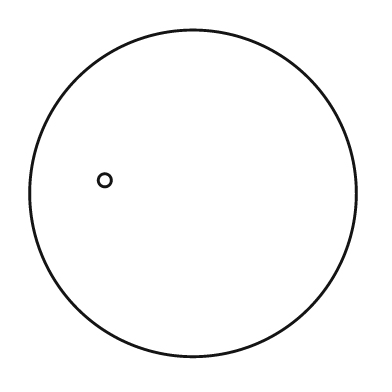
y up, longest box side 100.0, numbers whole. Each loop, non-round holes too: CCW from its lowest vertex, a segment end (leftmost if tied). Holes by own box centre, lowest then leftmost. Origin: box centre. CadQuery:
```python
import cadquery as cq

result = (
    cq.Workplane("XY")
    .moveTo(0.0, 0.0)
    .circle(50.0)
    .moveTo(-27.0, 4.0)
    .circle(2.0)
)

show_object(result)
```